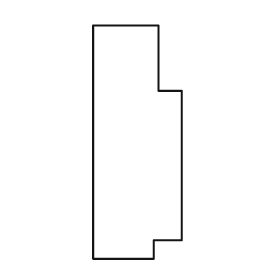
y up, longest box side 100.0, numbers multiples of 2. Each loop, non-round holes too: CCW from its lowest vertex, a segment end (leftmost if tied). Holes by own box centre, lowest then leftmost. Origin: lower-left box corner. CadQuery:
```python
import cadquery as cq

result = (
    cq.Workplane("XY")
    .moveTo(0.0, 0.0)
    .lineTo(26.0, 0.0)
    .lineTo(26.0, 8.0)
    .lineTo(38.0, 8.0)
    .lineTo(38.0, 72.0)
    .lineTo(28.0, 72.0)
    .lineTo(28.0, 100.0)
    .lineTo(0.0, 100.0)
    .close()
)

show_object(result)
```